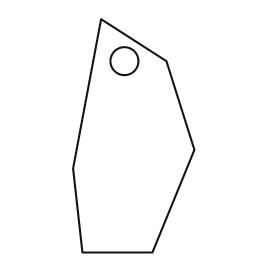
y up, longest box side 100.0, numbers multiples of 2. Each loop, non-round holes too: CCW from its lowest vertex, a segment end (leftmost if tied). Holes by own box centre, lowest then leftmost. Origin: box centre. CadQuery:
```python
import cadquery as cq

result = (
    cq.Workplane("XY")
    .moveTo(-22.0, -50.0)
    .lineTo(8.0, -50.0)
    .lineTo(26.0, -6.0)
    .lineTo(14.0, 32.0)
    .lineTo(-14.0, 50.0)
    .lineTo(-26.0, -14.0)
    .close()
    .moveTo(-4.0, 32.0)
    .circle(6.0)
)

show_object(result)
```